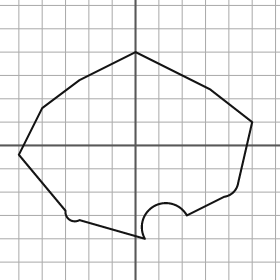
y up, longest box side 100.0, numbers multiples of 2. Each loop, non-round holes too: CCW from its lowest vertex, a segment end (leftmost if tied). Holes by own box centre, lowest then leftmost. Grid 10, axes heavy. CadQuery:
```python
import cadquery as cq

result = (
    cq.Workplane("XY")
    .moveTo(4.0, -40.0)
    .threePointArc((8.0, -26.0), (22.0, -30.0))
    .lineTo(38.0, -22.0)
    .threePointArc((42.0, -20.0), (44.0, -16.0))
    .lineTo(50.0, 10.0)
    .lineTo(32.0, 24.0)
    .lineTo(0.0, 40.0)
    .lineTo(-24.0, 28.0)
    .lineTo(-40.0, 16.0)
    .lineTo(-50.0, -4.0)
    .lineTo(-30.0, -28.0)
    .threePointArc((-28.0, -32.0), (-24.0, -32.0))
    .close()
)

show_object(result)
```